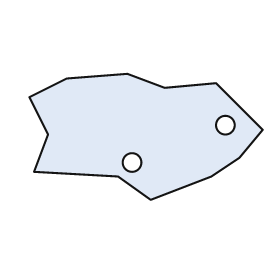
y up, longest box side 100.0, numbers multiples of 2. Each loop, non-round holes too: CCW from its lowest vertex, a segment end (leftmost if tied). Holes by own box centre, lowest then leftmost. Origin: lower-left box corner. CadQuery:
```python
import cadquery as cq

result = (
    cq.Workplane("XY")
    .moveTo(52.0, 0.0)
    .lineTo(78.0, 10.0)
    .lineTo(90.0, 18.0)
    .lineTo(100.0, 30.0)
    .lineTo(80.0, 50.0)
    .lineTo(58.0, 48.0)
    .lineTo(42.0, 54.0)
    .lineTo(16.0, 52.0)
    .lineTo(0.0, 44.0)
    .lineTo(8.0, 28.0)
    .lineTo(2.0, 12.0)
    .lineTo(38.0, 10.0)
    .close()
    .moveTo(44.0, 16.0)
    .circle(4.0)
    .moveTo(84.0, 32.0)
    .circle(4.0)
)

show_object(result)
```